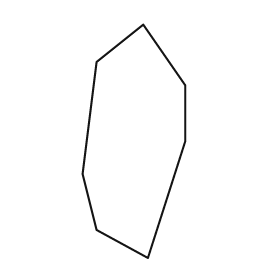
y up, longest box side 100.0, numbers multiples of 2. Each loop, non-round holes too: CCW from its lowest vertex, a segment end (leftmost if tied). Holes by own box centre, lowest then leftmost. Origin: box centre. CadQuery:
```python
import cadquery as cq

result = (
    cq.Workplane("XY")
    .moveTo(6.0, -50.0)
    .lineTo(22.0, 0.0)
    .lineTo(22.0, 24.0)
    .lineTo(4.0, 50.0)
    .lineTo(-16.0, 34.0)
    .lineTo(-22.0, -14.0)
    .lineTo(-16.0, -38.0)
    .close()
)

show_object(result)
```